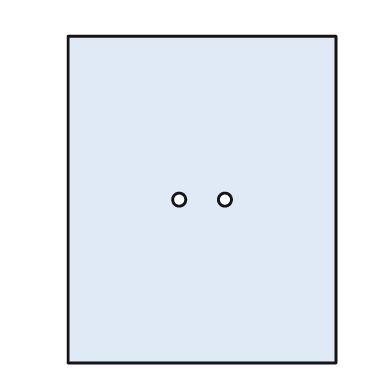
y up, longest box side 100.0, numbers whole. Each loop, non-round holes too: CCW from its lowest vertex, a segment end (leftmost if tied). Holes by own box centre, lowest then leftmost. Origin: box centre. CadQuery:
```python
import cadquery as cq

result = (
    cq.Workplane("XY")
    .moveTo(-41.0, -50.0)
    .lineTo(41.0, -50.0)
    .lineTo(41.0, 50.0)
    .lineTo(-41.0, 50.0)
    .close()
    .moveTo(-7.0, 0.0)
    .circle(2.0)
    .moveTo(7.0, 0.0)
    .circle(2.0)
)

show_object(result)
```